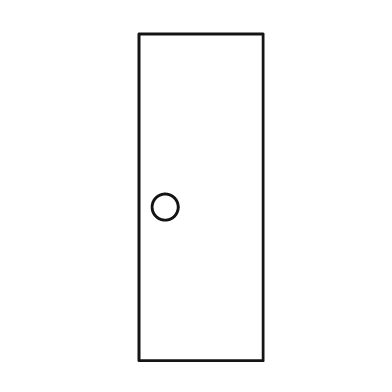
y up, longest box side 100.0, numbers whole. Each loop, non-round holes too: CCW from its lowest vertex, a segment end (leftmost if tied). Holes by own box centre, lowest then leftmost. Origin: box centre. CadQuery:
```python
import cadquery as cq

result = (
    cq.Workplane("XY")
    .moveTo(-19.0, -50.0)
    .lineTo(19.0, -50.0)
    .lineTo(19.0, 50.0)
    .lineTo(-19.0, 50.0)
    .close()
    .moveTo(-11.0, -3.0)
    .circle(4.0)
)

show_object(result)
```